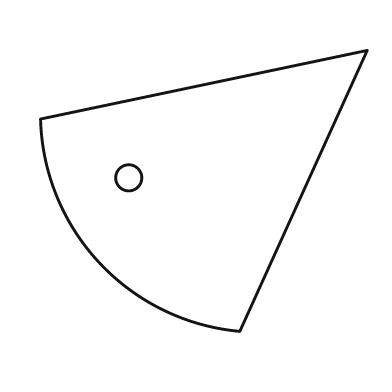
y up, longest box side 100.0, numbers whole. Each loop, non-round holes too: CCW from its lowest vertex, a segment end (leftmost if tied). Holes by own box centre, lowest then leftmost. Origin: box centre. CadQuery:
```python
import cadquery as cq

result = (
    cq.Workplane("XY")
    .moveTo(11.0, -43.0)
    .lineTo(50.0, 43.0)
    .lineTo(-50.0, 22.0)
    .threePointArc((-32.0, -22.0), (11.0, -43.0))
    .close()
    .moveTo(-23.0, 4.0)
    .circle(4.0)
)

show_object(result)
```